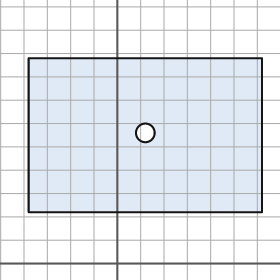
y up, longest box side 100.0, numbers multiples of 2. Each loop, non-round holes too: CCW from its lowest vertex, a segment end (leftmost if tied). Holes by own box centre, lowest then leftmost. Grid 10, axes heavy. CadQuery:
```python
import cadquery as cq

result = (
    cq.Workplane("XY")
    .moveTo(-38.0, 22.0)
    .lineTo(62.0, 22.0)
    .lineTo(62.0, 88.0)
    .lineTo(-38.0, 88.0)
    .close()
    .moveTo(12.0, 56.0)
    .circle(4.0)
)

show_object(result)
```